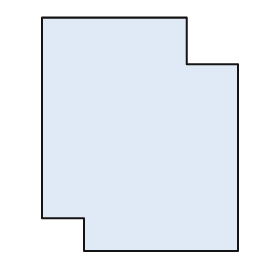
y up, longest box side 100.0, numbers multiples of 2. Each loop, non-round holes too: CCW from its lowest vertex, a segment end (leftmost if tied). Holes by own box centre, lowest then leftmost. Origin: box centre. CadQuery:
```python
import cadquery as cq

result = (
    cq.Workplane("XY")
    .moveTo(-24.0, -50.0)
    .lineTo(42.0, -50.0)
    .lineTo(42.0, 30.0)
    .lineTo(20.0, 30.0)
    .lineTo(20.0, 50.0)
    .lineTo(-42.0, 50.0)
    .lineTo(-42.0, -36.0)
    .lineTo(-24.0, -36.0)
    .close()
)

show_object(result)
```